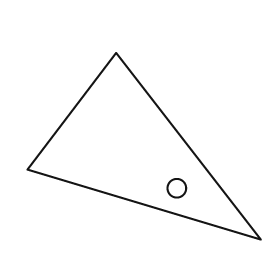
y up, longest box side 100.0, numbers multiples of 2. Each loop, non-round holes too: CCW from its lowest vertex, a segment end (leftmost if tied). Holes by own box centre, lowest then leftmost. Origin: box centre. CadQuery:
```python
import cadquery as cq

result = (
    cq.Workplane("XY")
    .moveTo(50.0, -40.0)
    .lineTo(-12.0, 40.0)
    .lineTo(-50.0, -10.0)
    .close()
    .moveTo(14.0, -18.0)
    .circle(4.0)
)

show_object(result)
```